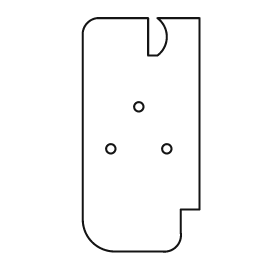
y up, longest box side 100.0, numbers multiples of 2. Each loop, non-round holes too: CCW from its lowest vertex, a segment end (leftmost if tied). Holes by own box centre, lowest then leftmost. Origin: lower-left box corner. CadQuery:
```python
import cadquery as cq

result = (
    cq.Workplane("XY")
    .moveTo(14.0, 0.0)
    .lineTo(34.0, 0.0)
    .threePointArc((40.0, 2.0), (42.0, 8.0))
    .lineTo(42.0, 18.0)
    .lineTo(50.0, 18.0)
    .lineTo(50.0, 100.0)
    .lineTo(32.0, 100.0)
    .threePointArc((36.0, 92.0), (32.0, 84.0))
    .lineTo(28.0, 84.0)
    .lineTo(28.0, 100.0)
    .lineTo(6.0, 100.0)
    .threePointArc((2.0, 98.0), (0.0, 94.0))
    .lineTo(0.0, 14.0)
    .threePointArc((4.0, 4.0), (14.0, 0.0))
    .close()
    .moveTo(12.0, 44.0)
    .circle(2.0)
    .moveTo(36.0, 44.0)
    .circle(2.0)
    .moveTo(24.0, 62.0)
    .circle(2.0)
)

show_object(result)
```